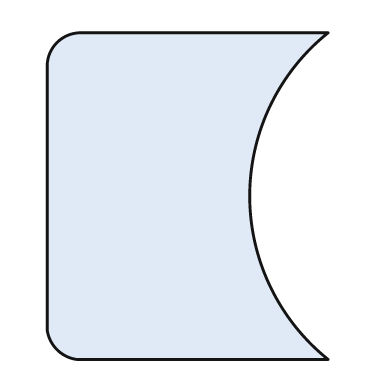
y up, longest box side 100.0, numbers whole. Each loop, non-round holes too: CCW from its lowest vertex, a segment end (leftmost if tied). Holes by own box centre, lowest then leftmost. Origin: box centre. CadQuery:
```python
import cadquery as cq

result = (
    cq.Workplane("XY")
    .moveTo(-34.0, -50.0)
    .lineTo(43.0, -50.0)
    .threePointArc((19.0, 0.0), (43.0, 50.0))
    .lineTo(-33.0, 50.0)
    .threePointArc((-40.0, 47.0), (-43.0, 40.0))
    .lineTo(-43.0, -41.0)
    .threePointArc((-40.0, -47.0), (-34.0, -50.0))
    .close()
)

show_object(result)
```